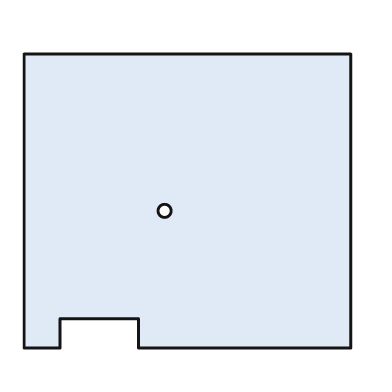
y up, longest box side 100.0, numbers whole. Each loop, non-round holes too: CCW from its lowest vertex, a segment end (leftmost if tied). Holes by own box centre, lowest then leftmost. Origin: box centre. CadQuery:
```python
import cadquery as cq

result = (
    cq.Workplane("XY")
    .moveTo(-50.0, -45.0)
    .lineTo(-39.0, -45.0)
    .lineTo(-39.0, -36.0)
    .lineTo(-15.0, -36.0)
    .lineTo(-15.0, -45.0)
    .lineTo(50.0, -45.0)
    .lineTo(50.0, 45.0)
    .lineTo(-50.0, 45.0)
    .close()
    .moveTo(-7.0, -3.0)
    .circle(2.0)
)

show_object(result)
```